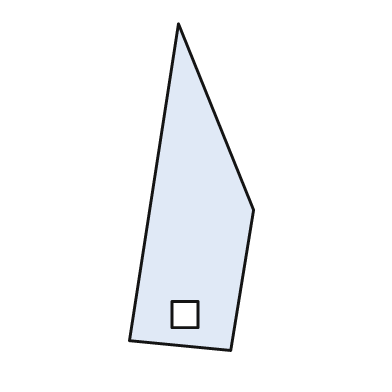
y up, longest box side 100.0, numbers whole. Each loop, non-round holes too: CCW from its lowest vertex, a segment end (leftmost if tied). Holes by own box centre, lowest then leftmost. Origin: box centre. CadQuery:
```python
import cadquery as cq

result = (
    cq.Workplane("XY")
    .moveTo(12.0, -50.0)
    .lineTo(19.0, -7.0)
    .lineTo(-4.0, 50.0)
    .lineTo(-19.0, -47.0)
    .close()
    .moveTo(-6.0, -43.0)
    .lineTo(2.0, -43.0)
    .lineTo(2.0, -35.0)
    .lineTo(-6.0, -35.0)
    .close()
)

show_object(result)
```